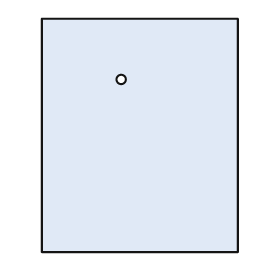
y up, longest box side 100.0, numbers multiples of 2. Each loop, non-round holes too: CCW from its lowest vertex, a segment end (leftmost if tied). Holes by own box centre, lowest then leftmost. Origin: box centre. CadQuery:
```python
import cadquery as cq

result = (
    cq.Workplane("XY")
    .moveTo(-42.0, -50.0)
    .lineTo(42.0, -50.0)
    .lineTo(42.0, 50.0)
    .lineTo(-42.0, 50.0)
    .close()
    .moveTo(-8.0, 24.0)
    .circle(2.0)
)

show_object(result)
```